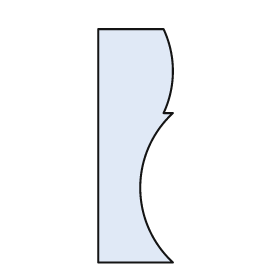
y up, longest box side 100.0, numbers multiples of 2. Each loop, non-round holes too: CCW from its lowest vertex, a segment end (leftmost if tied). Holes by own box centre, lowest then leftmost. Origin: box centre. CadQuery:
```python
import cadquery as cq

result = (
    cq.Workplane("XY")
    .moveTo(-16.0, -50.0)
    .lineTo(16.0, -50.0)
    .threePointArc((2.0, -18.0), (16.0, 14.0))
    .lineTo(12.0, 14.0)
    .threePointArc((16.0, 32.0), (12.0, 50.0))
    .lineTo(-16.0, 50.0)
    .close()
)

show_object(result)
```